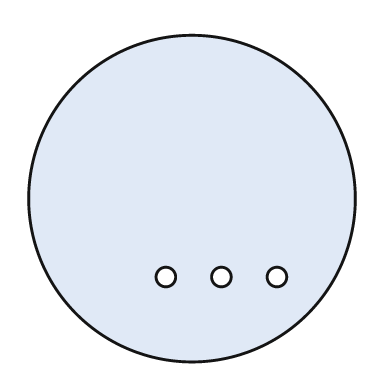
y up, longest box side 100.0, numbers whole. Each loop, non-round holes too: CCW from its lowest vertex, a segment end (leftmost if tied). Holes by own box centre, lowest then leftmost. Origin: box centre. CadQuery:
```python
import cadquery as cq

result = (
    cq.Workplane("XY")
    .moveTo(0.0, 0.0)
    .circle(50.0)
    .moveTo(-8.0, -24.0)
    .circle(3.0)
    .moveTo(9.0, -24.0)
    .circle(3.0)
    .moveTo(26.0, -24.0)
    .circle(3.0)
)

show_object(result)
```